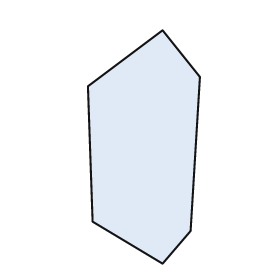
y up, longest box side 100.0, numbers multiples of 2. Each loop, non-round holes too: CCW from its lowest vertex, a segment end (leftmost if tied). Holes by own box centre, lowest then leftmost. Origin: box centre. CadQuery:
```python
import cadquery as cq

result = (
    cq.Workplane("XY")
    .moveTo(8.0, -50.0)
    .lineTo(20.0, -36.0)
    .lineTo(24.0, 30.0)
    .lineTo(8.0, 50.0)
    .lineTo(-24.0, 26.0)
    .lineTo(-22.0, -32.0)
    .close()
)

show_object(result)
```